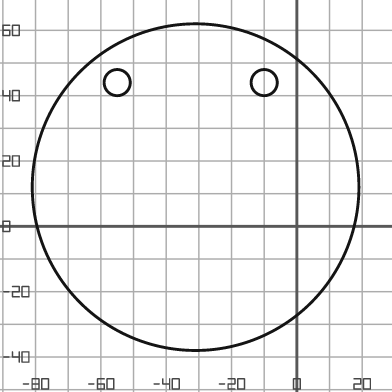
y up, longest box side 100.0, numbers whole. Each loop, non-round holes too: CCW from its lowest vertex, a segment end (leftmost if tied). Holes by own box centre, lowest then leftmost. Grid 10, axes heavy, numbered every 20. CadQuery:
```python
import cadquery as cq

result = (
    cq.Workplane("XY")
    .moveTo(-31.0, 12.0)
    .circle(50.0)
    .moveTo(-55.0, 44.0)
    .circle(4.0)
    .moveTo(-10.0, 44.0)
    .circle(4.0)
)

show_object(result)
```